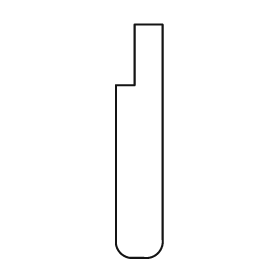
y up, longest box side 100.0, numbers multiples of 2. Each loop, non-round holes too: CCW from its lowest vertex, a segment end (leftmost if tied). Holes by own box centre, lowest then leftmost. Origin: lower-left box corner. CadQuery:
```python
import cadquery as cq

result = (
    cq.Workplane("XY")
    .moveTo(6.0, 0.0)
    .lineTo(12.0, 0.0)
    .threePointArc((18.0, 2.0), (20.0, 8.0))
    .lineTo(20.0, 100.0)
    .lineTo(8.0, 100.0)
    .lineTo(8.0, 74.0)
    .lineTo(0.0, 74.0)
    .lineTo(0.0, 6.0)
    .threePointArc((2.0, 2.0), (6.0, 0.0))
    .close()
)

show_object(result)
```